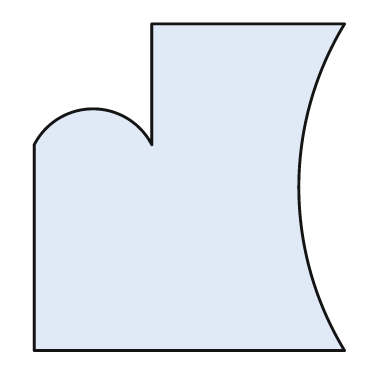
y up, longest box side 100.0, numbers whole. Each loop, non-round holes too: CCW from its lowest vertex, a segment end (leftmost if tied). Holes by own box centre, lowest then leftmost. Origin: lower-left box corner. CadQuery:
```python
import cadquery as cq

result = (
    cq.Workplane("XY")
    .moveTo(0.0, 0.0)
    .lineTo(95.0, 0.0)
    .threePointArc((81.0, 50.0), (95.0, 100.0))
    .lineTo(36.0, 100.0)
    .lineTo(36.0, 63.0)
    .threePointArc((18.0, 74.0), (0.0, 63.0))
    .close()
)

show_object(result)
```